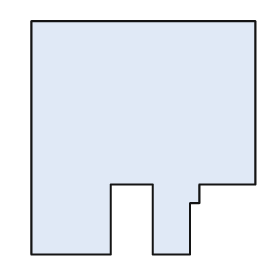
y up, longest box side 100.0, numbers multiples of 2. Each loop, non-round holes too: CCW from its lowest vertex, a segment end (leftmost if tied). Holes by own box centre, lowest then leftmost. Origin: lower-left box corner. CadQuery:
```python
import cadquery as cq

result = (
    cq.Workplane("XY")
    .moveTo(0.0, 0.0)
    .lineTo(34.0, 0.0)
    .lineTo(34.0, 30.0)
    .lineTo(52.0, 30.0)
    .lineTo(52.0, 0.0)
    .lineTo(68.0, 0.0)
    .lineTo(68.0, 22.0)
    .lineTo(72.0, 22.0)
    .lineTo(72.0, 30.0)
    .lineTo(96.0, 30.0)
    .lineTo(96.0, 100.0)
    .lineTo(0.0, 100.0)
    .close()
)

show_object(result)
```